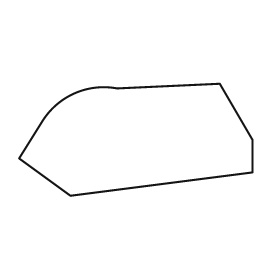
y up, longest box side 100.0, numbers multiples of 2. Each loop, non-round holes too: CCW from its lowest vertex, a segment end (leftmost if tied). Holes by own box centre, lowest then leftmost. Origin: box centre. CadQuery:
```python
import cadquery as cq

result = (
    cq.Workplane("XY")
    .moveTo(-28.0, -24.0)
    .lineTo(50.0, -14.0)
    .lineTo(50.0, 0.0)
    .lineTo(36.0, 24.0)
    .lineTo(-8.0, 22.0)
    .threePointArc((-26.0, 20.0), (-40.0, 8.0))
    .lineTo(-50.0, -8.0)
    .close()
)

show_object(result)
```